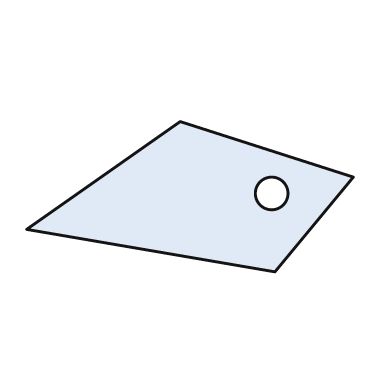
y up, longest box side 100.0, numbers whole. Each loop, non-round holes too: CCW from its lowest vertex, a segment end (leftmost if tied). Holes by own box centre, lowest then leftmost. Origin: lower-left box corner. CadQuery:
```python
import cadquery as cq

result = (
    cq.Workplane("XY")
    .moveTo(76.0, 0.0)
    .lineTo(100.0, 29.0)
    .lineTo(47.0, 46.0)
    .lineTo(0.0, 13.0)
    .close()
    .moveTo(75.0, 24.0)
    .circle(5.0)
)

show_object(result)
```